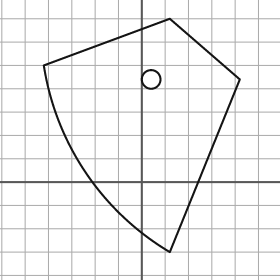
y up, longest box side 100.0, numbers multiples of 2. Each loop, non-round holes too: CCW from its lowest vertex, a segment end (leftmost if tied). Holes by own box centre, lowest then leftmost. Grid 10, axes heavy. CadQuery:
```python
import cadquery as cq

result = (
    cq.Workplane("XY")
    .moveTo(12.0, -30.0)
    .lineTo(42.0, 44.0)
    .lineTo(12.0, 70.0)
    .lineTo(-42.0, 50.0)
    .threePointArc((-24.0, 4.0), (12.0, -30.0))
    .close()
    .moveTo(4.0, 44.0)
    .circle(4.0)
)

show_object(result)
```